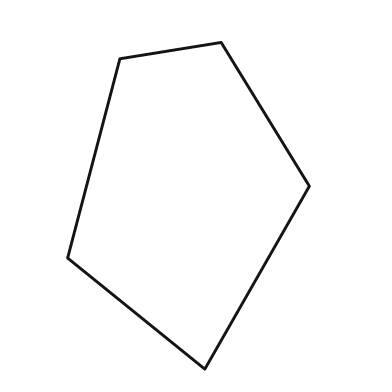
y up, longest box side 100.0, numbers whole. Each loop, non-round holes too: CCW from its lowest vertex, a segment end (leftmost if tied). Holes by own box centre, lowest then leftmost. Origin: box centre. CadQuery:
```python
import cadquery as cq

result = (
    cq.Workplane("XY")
    .moveTo(5.0, -50.0)
    .lineTo(37.0, 6.0)
    .lineTo(10.0, 50.0)
    .lineTo(-21.0, 45.0)
    .lineTo(-37.0, -16.0)
    .close()
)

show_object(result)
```